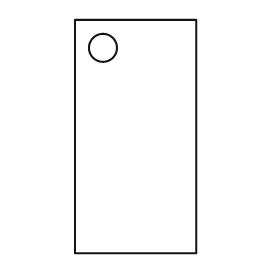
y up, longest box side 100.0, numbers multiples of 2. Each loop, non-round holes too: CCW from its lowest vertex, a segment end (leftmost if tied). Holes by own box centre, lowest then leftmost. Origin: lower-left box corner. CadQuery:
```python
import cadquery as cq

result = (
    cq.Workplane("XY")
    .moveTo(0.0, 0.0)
    .lineTo(52.0, 0.0)
    .lineTo(52.0, 100.0)
    .lineTo(0.0, 100.0)
    .close()
    .moveTo(12.0, 88.0)
    .circle(6.0)
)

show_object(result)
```